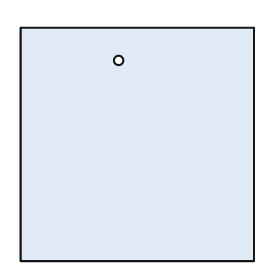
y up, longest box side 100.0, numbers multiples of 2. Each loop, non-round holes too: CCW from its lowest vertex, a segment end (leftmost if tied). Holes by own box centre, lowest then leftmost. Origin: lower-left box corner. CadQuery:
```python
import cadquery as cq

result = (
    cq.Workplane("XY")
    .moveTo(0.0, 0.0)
    .lineTo(100.0, 0.0)
    .lineTo(100.0, 100.0)
    .lineTo(0.0, 100.0)
    .close()
    .moveTo(42.0, 86.0)
    .circle(2.0)
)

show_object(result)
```